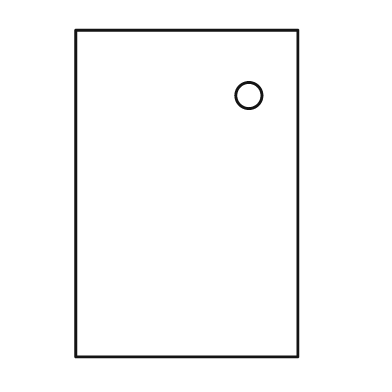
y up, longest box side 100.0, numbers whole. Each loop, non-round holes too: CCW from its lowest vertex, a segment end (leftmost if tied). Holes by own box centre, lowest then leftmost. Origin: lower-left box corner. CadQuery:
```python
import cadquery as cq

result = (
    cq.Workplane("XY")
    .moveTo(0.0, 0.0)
    .lineTo(68.0, 0.0)
    .lineTo(68.0, 100.0)
    .lineTo(0.0, 100.0)
    .close()
    .moveTo(53.0, 80.0)
    .circle(4.0)
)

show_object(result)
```